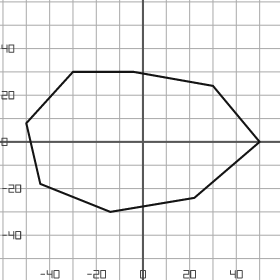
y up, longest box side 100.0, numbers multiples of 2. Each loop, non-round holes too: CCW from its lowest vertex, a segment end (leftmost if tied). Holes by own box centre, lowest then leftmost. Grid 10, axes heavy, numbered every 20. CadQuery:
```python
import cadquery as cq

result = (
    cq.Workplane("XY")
    .moveTo(-14.0, -30.0)
    .lineTo(22.0, -24.0)
    .lineTo(50.0, 0.0)
    .lineTo(30.0, 24.0)
    .lineTo(-4.0, 30.0)
    .lineTo(-30.0, 30.0)
    .lineTo(-50.0, 8.0)
    .lineTo(-44.0, -18.0)
    .close()
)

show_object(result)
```